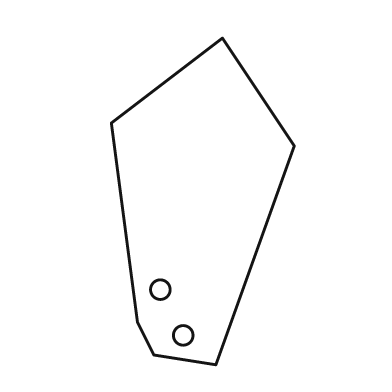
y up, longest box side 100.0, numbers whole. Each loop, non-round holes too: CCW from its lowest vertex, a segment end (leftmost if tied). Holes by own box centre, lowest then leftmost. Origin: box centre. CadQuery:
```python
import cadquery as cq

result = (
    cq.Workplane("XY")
    .moveTo(4.0, -50.0)
    .lineTo(28.0, 17.0)
    .lineTo(6.0, 50.0)
    .lineTo(-28.0, 24.0)
    .lineTo(-20.0, -37.0)
    .lineTo(-15.0, -47.0)
    .close()
    .moveTo(-6.0, -41.0)
    .circle(3.0)
    .moveTo(-13.0, -27.0)
    .circle(3.0)
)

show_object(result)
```